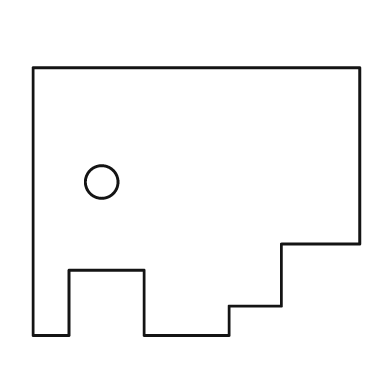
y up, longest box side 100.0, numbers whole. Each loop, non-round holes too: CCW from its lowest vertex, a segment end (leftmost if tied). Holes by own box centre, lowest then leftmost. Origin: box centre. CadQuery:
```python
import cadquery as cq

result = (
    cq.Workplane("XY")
    .moveTo(-50.0, -41.0)
    .lineTo(-39.0, -41.0)
    .lineTo(-39.0, -21.0)
    .lineTo(-16.0, -21.0)
    .lineTo(-16.0, -41.0)
    .lineTo(10.0, -41.0)
    .lineTo(10.0, -32.0)
    .lineTo(26.0, -32.0)
    .lineTo(26.0, -13.0)
    .lineTo(50.0, -13.0)
    .lineTo(50.0, 41.0)
    .lineTo(-50.0, 41.0)
    .close()
    .moveTo(-29.0, 6.0)
    .circle(5.0)
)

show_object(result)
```